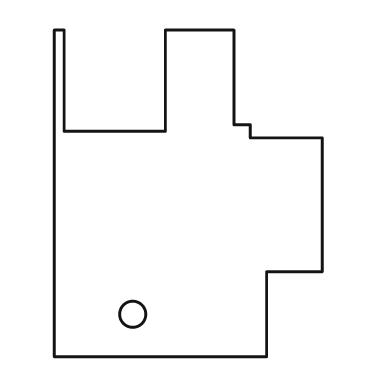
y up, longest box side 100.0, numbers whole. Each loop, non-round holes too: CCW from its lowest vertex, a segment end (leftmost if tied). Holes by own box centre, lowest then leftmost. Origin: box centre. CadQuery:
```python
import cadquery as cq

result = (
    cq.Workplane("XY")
    .moveTo(-41.0, -50.0)
    .lineTo(24.0, -50.0)
    .lineTo(24.0, -24.0)
    .lineTo(41.0, -24.0)
    .lineTo(41.0, 17.0)
    .lineTo(19.0, 17.0)
    .lineTo(19.0, 21.0)
    .lineTo(14.0, 21.0)
    .lineTo(14.0, 50.0)
    .lineTo(-7.0, 50.0)
    .lineTo(-7.0, 19.0)
    .lineTo(-38.0, 19.0)
    .lineTo(-38.0, 50.0)
    .lineTo(-41.0, 50.0)
    .close()
    .moveTo(-17.0, -37.0)
    .circle(4.0)
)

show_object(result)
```